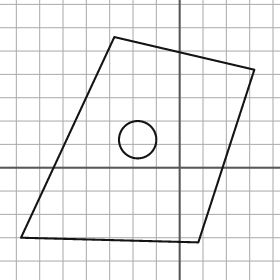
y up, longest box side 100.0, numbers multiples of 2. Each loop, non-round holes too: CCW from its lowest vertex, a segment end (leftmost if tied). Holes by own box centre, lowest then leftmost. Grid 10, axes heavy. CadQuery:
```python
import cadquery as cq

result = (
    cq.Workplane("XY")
    .moveTo(8.0, -32.0)
    .lineTo(32.0, 42.0)
    .lineTo(-28.0, 56.0)
    .lineTo(-68.0, -30.0)
    .close()
    .moveTo(-18.0, 12.0)
    .circle(8.0)
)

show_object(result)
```